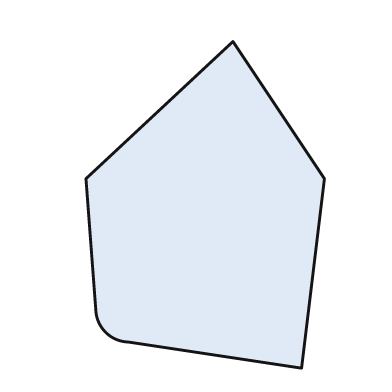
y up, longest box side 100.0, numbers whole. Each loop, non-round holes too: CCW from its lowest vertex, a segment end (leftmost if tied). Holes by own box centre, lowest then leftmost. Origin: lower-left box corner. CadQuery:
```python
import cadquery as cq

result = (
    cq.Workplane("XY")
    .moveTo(66.0, 0.0)
    .lineTo(73.0, 58.0)
    .lineTo(45.0, 100.0)
    .lineTo(0.0, 58.0)
    .lineTo(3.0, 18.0)
    .threePointArc((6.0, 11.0), (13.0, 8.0))
    .close()
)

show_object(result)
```